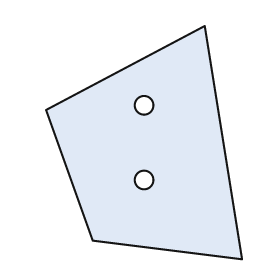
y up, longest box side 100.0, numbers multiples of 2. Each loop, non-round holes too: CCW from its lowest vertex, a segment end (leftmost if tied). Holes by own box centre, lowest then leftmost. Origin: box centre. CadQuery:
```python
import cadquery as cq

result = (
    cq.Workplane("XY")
    .moveTo(42.0, -50.0)
    .lineTo(26.0, 50.0)
    .lineTo(-42.0, 14.0)
    .lineTo(-22.0, -42.0)
    .close()
    .moveTo(0.0, -16.0)
    .circle(4.0)
    .moveTo(0.0, 16.0)
    .circle(4.0)
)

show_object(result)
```